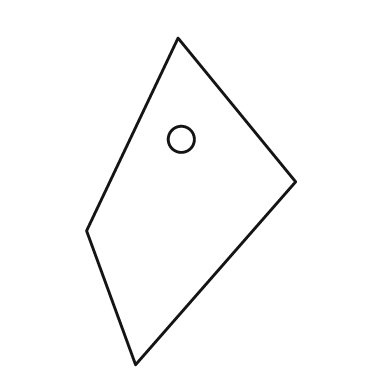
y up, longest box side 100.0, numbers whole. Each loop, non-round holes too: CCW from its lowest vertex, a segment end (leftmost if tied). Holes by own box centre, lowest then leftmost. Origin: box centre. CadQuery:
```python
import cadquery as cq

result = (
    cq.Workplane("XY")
    .moveTo(-17.0, -50.0)
    .lineTo(32.0, 6.0)
    .lineTo(-4.0, 50.0)
    .lineTo(-32.0, -9.0)
    .close()
    .moveTo(-3.0, 19.0)
    .circle(4.0)
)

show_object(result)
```